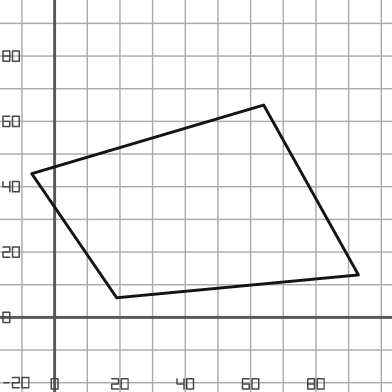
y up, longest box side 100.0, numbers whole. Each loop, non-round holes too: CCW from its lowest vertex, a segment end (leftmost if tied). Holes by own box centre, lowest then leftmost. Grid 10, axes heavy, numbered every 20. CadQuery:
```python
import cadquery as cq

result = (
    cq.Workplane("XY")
    .moveTo(19.0, 6.0)
    .lineTo(93.0, 13.0)
    .lineTo(64.0, 65.0)
    .lineTo(-7.0, 44.0)
    .close()
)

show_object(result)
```